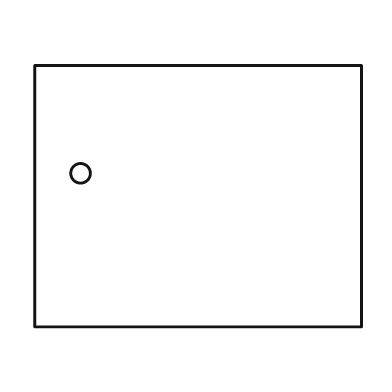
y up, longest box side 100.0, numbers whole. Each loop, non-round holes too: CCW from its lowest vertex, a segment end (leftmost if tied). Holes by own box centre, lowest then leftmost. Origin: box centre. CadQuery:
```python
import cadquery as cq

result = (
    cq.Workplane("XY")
    .moveTo(-50.0, -40.0)
    .lineTo(50.0, -40.0)
    .lineTo(50.0, 40.0)
    .lineTo(-50.0, 40.0)
    .close()
    .moveTo(-36.0, 7.0)
    .circle(3.0)
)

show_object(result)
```